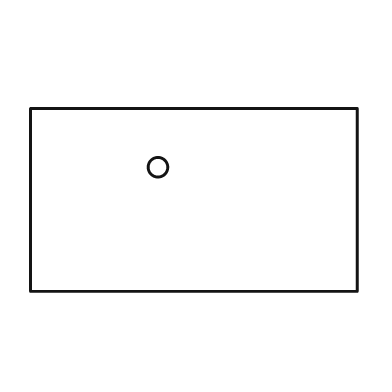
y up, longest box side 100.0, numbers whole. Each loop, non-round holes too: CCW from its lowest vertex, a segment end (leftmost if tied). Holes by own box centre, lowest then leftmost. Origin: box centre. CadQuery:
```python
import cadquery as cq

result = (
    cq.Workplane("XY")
    .moveTo(-50.0, -28.0)
    .lineTo(50.0, -28.0)
    .lineTo(50.0, 28.0)
    .lineTo(-50.0, 28.0)
    .close()
    .moveTo(-11.0, 10.0)
    .circle(3.0)
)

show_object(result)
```